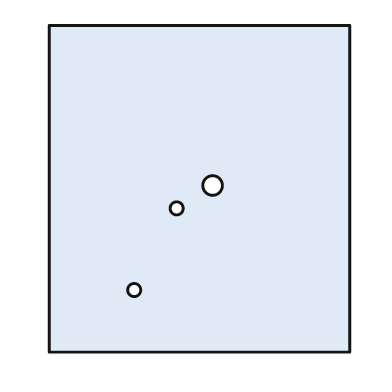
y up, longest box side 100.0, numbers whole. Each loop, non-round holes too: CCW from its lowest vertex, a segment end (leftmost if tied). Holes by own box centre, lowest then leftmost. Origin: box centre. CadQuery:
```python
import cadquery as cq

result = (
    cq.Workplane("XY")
    .moveTo(-46.0, -50.0)
    .lineTo(46.0, -50.0)
    .lineTo(46.0, 50.0)
    .lineTo(-46.0, 50.0)
    .close()
    .moveTo(-20.0, -31.0)
    .circle(2.0)
    .moveTo(-7.0, -6.0)
    .circle(2.0)
    .moveTo(4.0, 1.0)
    .circle(3.0)
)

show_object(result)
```